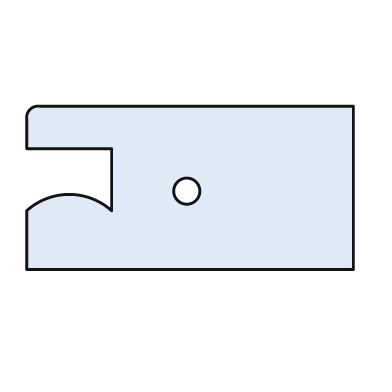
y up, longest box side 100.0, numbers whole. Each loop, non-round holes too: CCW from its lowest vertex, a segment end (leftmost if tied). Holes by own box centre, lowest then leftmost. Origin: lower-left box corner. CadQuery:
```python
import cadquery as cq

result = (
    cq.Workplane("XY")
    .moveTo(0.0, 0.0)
    .lineTo(100.0, 0.0)
    .lineTo(100.0, 50.0)
    .lineTo(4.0, 50.0)
    .threePointArc((1.0, 49.0), (0.0, 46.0))
    .lineTo(0.0, 37.0)
    .lineTo(26.0, 37.0)
    .lineTo(26.0, 18.0)
    .threePointArc((13.0, 23.0), (0.0, 18.0))
    .close()
    .moveTo(49.0, 24.0)
    .circle(4.0)
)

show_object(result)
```